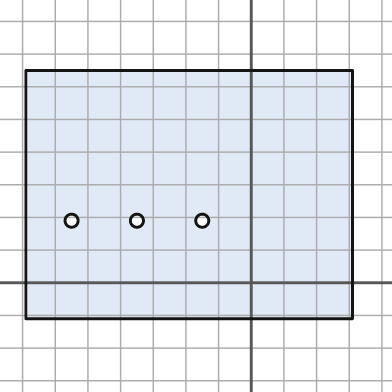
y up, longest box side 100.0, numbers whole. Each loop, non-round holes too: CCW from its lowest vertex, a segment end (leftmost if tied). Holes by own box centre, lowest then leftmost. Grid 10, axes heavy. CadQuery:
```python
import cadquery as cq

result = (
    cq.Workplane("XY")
    .moveTo(-69.0, -11.0)
    .lineTo(31.0, -11.0)
    .lineTo(31.0, 65.0)
    .lineTo(-69.0, 65.0)
    .close()
    .moveTo(-55.0, 19.0)
    .circle(2.0)
    .moveTo(-35.0, 19.0)
    .circle(2.0)
    .moveTo(-15.0, 19.0)
    .circle(2.0)
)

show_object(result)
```